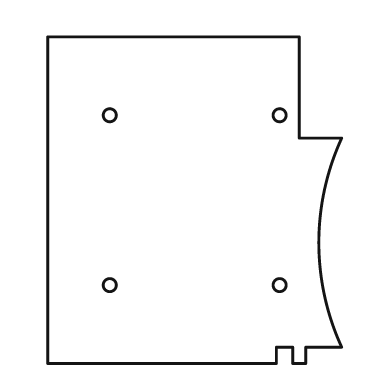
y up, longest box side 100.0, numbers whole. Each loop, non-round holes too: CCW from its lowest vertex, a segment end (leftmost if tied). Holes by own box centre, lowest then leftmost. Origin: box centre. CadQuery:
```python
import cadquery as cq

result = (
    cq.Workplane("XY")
    .moveTo(-45.0, -50.0)
    .lineTo(25.0, -50.0)
    .lineTo(25.0, -45.0)
    .lineTo(30.0, -45.0)
    .lineTo(30.0, -50.0)
    .lineTo(34.0, -50.0)
    .lineTo(34.0, -45.0)
    .lineTo(45.0, -45.0)
    .threePointArc((38.0, -13.0), (45.0, 19.0))
    .lineTo(32.0, 19.0)
    .lineTo(32.0, 50.0)
    .lineTo(-45.0, 50.0)
    .close()
    .moveTo(-26.0, -26.0)
    .circle(2.0)
    .moveTo(26.0, -26.0)
    .circle(2.0)
    .moveTo(-26.0, 26.0)
    .circle(2.0)
    .moveTo(26.0, 26.0)
    .circle(2.0)
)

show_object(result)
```